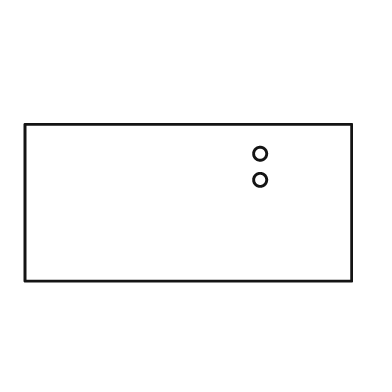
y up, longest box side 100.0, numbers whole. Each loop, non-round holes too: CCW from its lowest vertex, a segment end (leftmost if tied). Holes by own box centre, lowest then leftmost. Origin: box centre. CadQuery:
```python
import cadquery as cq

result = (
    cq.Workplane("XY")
    .moveTo(-50.0, -24.0)
    .lineTo(50.0, -24.0)
    .lineTo(50.0, 24.0)
    .lineTo(-50.0, 24.0)
    .close()
    .moveTo(22.0, 7.0)
    .circle(2.0)
    .moveTo(22.0, 15.0)
    .circle(2.0)
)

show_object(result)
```